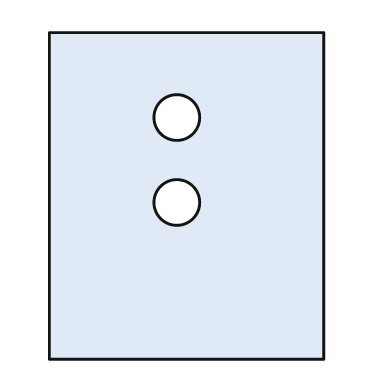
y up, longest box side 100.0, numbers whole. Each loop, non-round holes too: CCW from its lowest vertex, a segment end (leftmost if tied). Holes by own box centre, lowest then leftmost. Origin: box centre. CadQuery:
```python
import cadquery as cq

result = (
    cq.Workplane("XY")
    .moveTo(-42.0, -50.0)
    .lineTo(42.0, -50.0)
    .lineTo(42.0, 50.0)
    .lineTo(-42.0, 50.0)
    .close()
    .moveTo(-3.0, -2.0)
    .circle(7.0)
    .moveTo(-3.0, 24.0)
    .circle(7.0)
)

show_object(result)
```